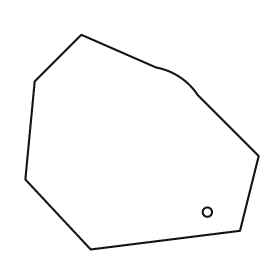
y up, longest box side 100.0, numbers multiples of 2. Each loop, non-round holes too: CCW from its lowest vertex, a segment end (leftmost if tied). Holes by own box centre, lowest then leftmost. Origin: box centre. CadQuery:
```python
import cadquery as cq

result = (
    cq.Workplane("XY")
    .moveTo(-22.0, -46.0)
    .lineTo(42.0, -38.0)
    .lineTo(50.0, -6.0)
    .lineTo(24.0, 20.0)
    .threePointArc((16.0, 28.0), (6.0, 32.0))
    .lineTo(-26.0, 46.0)
    .lineTo(-46.0, 26.0)
    .lineTo(-50.0, -16.0)
    .close()
    .moveTo(28.0, -30.0)
    .circle(2.0)
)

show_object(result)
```